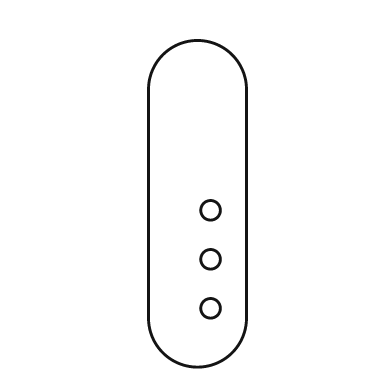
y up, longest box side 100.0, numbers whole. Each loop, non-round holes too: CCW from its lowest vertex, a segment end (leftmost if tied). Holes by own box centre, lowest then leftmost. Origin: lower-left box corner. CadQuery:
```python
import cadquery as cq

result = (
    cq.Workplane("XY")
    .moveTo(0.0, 15.0)
    .threePointArc((15.0, 0.0), (30.0, 15.0))
    .lineTo(30.0, 85.0)
    .threePointArc((15.0, 100.0), (0.0, 85.0))
    .close()
    .moveTo(19.0, 18.0)
    .circle(3.0)
    .moveTo(19.0, 33.0)
    .circle(3.0)
    .moveTo(19.0, 48.0)
    .circle(3.0)
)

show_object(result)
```